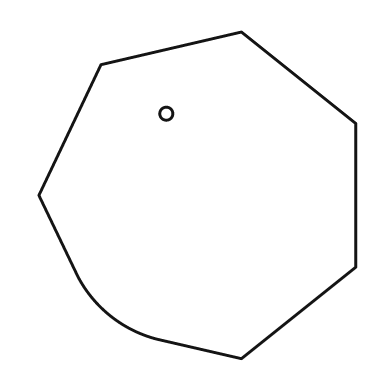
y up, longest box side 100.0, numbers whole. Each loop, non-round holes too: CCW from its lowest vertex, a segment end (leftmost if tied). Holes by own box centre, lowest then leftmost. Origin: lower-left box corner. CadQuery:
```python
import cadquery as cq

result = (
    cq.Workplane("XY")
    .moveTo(62.0, 0.0)
    .lineTo(97.0, 28.0)
    .lineTo(97.0, 72.0)
    .lineTo(62.0, 100.0)
    .lineTo(19.0, 90.0)
    .lineTo(0.0, 50.0)
    .lineTo(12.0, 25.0)
    .threePointArc((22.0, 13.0), (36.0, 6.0))
    .close()
    .moveTo(39.0, 75.0)
    .circle(2.0)
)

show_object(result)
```